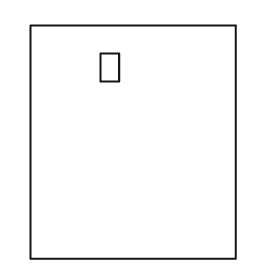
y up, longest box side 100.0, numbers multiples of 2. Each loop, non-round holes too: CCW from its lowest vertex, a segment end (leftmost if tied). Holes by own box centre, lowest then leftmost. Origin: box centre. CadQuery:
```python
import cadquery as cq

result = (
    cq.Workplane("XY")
    .moveTo(-44.0, -50.0)
    .lineTo(44.0, -50.0)
    .lineTo(44.0, 50.0)
    .lineTo(-44.0, 50.0)
    .close()
    .moveTo(-14.0, 26.0)
    .lineTo(-6.0, 26.0)
    .lineTo(-6.0, 38.0)
    .lineTo(-14.0, 38.0)
    .close()
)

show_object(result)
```